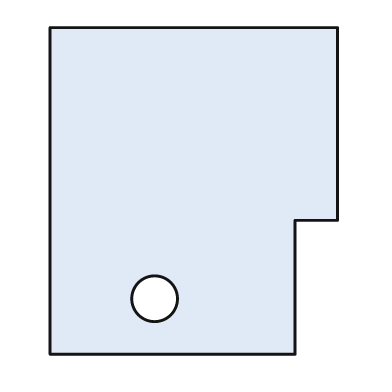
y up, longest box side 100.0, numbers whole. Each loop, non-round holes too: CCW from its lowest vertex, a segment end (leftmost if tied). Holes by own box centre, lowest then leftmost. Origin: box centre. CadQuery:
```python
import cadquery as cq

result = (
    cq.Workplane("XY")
    .moveTo(-44.0, -50.0)
    .lineTo(31.0, -50.0)
    .lineTo(31.0, -9.0)
    .lineTo(44.0, -9.0)
    .lineTo(44.0, 50.0)
    .lineTo(-44.0, 50.0)
    .close()
    .moveTo(-12.0, -33.0)
    .circle(7.0)
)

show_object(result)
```